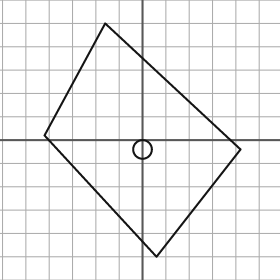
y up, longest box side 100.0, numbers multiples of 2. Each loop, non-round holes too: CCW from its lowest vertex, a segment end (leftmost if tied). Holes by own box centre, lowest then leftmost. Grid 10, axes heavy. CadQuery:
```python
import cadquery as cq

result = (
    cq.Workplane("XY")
    .moveTo(6.0, -50.0)
    .lineTo(42.0, -4.0)
    .lineTo(-16.0, 50.0)
    .lineTo(-42.0, 2.0)
    .close()
    .moveTo(0.0, -4.0)
    .circle(4.0)
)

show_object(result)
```